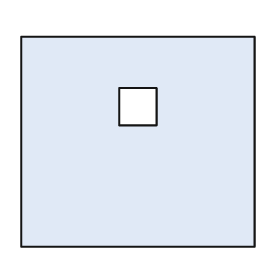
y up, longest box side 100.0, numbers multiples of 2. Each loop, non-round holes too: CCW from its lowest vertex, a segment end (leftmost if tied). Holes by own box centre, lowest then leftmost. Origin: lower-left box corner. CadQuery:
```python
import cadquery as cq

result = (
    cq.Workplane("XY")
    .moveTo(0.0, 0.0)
    .lineTo(100.0, 0.0)
    .lineTo(100.0, 90.0)
    .lineTo(0.0, 90.0)
    .close()
    .moveTo(42.0, 52.0)
    .lineTo(58.0, 52.0)
    .lineTo(58.0, 68.0)
    .lineTo(42.0, 68.0)
    .close()
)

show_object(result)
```